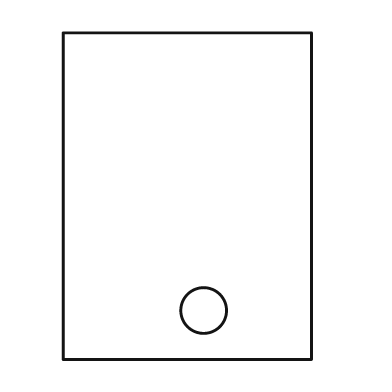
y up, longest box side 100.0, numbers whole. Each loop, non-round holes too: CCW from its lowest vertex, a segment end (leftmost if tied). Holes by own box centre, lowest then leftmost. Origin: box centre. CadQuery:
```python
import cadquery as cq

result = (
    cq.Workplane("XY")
    .moveTo(-38.0, -50.0)
    .lineTo(38.0, -50.0)
    .lineTo(38.0, 50.0)
    .lineTo(-38.0, 50.0)
    .close()
    .moveTo(5.0, -35.0)
    .circle(7.0)
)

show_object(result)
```